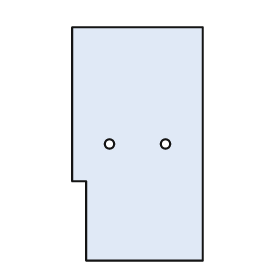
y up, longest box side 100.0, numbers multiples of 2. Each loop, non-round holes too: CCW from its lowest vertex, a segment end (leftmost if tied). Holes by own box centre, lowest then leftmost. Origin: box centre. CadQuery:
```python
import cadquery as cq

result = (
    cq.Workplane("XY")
    .moveTo(-22.0, -50.0)
    .lineTo(28.0, -50.0)
    .lineTo(28.0, 50.0)
    .lineTo(-28.0, 50.0)
    .lineTo(-28.0, -16.0)
    .lineTo(-22.0, -16.0)
    .close()
    .moveTo(-12.0, 0.0)
    .circle(2.0)
    .moveTo(12.0, 0.0)
    .circle(2.0)
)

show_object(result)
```